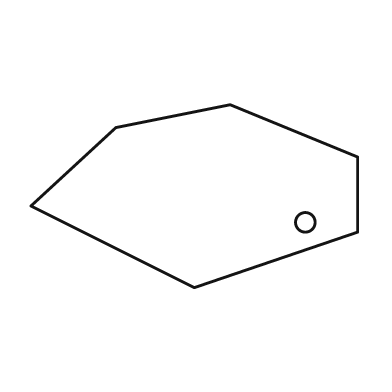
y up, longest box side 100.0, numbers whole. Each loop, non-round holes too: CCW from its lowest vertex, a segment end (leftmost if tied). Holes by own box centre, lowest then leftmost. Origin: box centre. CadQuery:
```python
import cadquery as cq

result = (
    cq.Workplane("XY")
    .moveTo(0.0, -28.0)
    .lineTo(50.0, -11.0)
    .lineTo(50.0, 12.0)
    .lineTo(11.0, 28.0)
    .lineTo(-24.0, 21.0)
    .lineTo(-50.0, -3.0)
    .close()
    .moveTo(34.0, -8.0)
    .circle(3.0)
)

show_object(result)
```